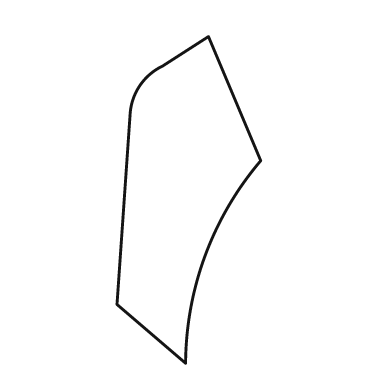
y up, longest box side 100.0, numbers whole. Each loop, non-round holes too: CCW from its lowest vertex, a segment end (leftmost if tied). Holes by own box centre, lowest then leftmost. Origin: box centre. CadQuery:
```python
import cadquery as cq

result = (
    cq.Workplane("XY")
    .moveTo(-1.0, -50.0)
    .threePointArc((5.0, -17.0), (22.0, 12.0))
    .lineTo(6.0, 50.0)
    .lineTo(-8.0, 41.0)
    .threePointArc((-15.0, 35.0), (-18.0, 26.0))
    .lineTo(-22.0, -32.0)
    .close()
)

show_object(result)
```